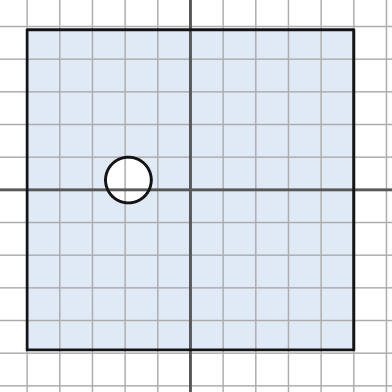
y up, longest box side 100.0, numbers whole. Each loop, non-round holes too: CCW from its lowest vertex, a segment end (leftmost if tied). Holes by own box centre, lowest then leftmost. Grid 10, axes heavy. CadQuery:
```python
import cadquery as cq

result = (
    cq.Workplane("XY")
    .moveTo(-50.0, -49.0)
    .lineTo(50.0, -49.0)
    .lineTo(50.0, 49.0)
    .lineTo(-50.0, 49.0)
    .close()
    .moveTo(-19.0, 3.0)
    .circle(7.0)
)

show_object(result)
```